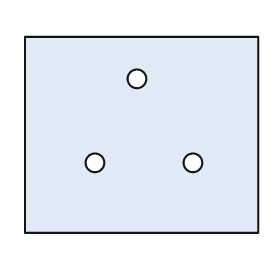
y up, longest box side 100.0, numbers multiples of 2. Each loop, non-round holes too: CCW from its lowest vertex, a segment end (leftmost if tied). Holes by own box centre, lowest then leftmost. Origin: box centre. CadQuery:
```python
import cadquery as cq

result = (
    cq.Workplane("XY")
    .moveTo(-50.0, -42.0)
    .lineTo(50.0, -42.0)
    .lineTo(50.0, 42.0)
    .lineTo(-50.0, 42.0)
    .close()
    .moveTo(-20.0, -12.0)
    .circle(4.0)
    .moveTo(22.0, -12.0)
    .circle(4.0)
    .moveTo(-2.0, 24.0)
    .circle(4.0)
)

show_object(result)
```